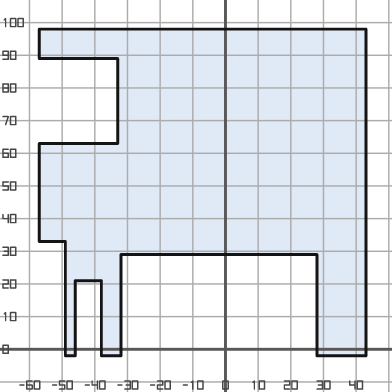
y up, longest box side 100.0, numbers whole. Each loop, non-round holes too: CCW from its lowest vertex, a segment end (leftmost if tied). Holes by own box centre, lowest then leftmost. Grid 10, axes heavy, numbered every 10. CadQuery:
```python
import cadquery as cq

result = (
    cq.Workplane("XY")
    .moveTo(-49.0, -2.0)
    .lineTo(-46.0, -2.0)
    .lineTo(-46.0, 21.0)
    .lineTo(-38.0, 21.0)
    .lineTo(-38.0, -2.0)
    .lineTo(-32.0, -2.0)
    .lineTo(-32.0, 29.0)
    .lineTo(28.0, 29.0)
    .lineTo(28.0, -2.0)
    .lineTo(43.0, -2.0)
    .lineTo(43.0, 98.0)
    .lineTo(-57.0, 98.0)
    .lineTo(-57.0, 89.0)
    .lineTo(-33.0, 89.0)
    .lineTo(-33.0, 63.0)
    .lineTo(-57.0, 63.0)
    .lineTo(-57.0, 33.0)
    .lineTo(-49.0, 33.0)
    .close()
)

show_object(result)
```